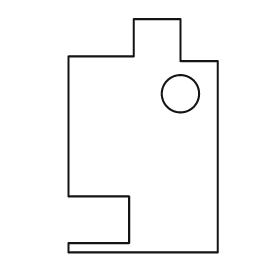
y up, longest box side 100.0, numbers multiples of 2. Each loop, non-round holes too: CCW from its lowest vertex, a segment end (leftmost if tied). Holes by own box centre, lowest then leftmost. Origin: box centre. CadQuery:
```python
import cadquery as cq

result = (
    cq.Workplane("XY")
    .moveTo(-32.0, -50.0)
    .lineTo(32.0, -50.0)
    .lineTo(32.0, 32.0)
    .lineTo(16.0, 32.0)
    .lineTo(16.0, 50.0)
    .lineTo(-4.0, 50.0)
    .lineTo(-4.0, 34.0)
    .lineTo(-32.0, 34.0)
    .lineTo(-32.0, -26.0)
    .lineTo(-6.0, -26.0)
    .lineTo(-6.0, -46.0)
    .lineTo(-32.0, -46.0)
    .close()
    .moveTo(16.0, 18.0)
    .circle(8.0)
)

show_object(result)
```